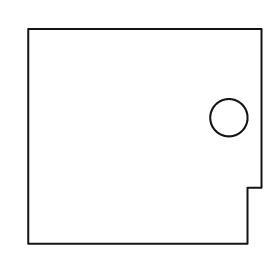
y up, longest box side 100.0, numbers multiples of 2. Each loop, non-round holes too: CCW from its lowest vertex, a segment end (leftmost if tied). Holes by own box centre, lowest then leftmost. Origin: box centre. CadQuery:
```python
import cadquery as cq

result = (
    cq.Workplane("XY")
    .moveTo(-50.0, -46.0)
    .lineTo(44.0, -46.0)
    .lineTo(44.0, -22.0)
    .lineTo(50.0, -22.0)
    .lineTo(50.0, 46.0)
    .lineTo(-50.0, 46.0)
    .close()
    .moveTo(36.0, 8.0)
    .circle(8.0)
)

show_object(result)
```